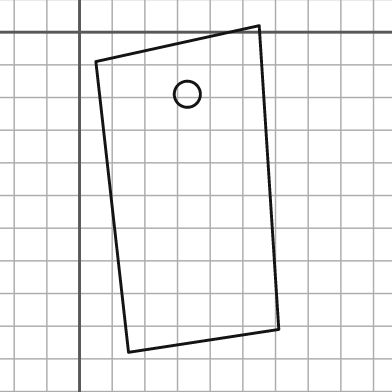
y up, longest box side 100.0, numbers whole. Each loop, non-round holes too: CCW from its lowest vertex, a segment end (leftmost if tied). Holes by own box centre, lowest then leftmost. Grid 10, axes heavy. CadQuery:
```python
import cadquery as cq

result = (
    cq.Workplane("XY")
    .moveTo(15.0, -98.0)
    .lineTo(61.0, -91.0)
    .lineTo(55.0, 2.0)
    .lineTo(5.0, -9.0)
    .close()
    .moveTo(33.0, -19.0)
    .circle(4.0)
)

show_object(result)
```